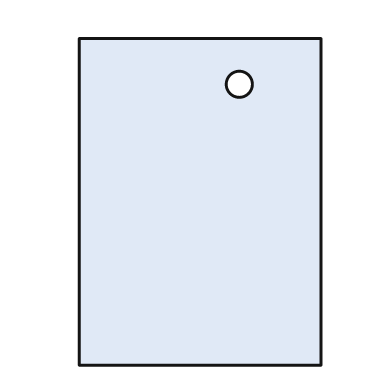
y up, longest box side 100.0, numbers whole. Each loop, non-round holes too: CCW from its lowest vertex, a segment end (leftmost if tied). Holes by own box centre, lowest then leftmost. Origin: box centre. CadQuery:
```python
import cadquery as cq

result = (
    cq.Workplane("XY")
    .moveTo(-37.0, -50.0)
    .lineTo(37.0, -50.0)
    .lineTo(37.0, 50.0)
    .lineTo(-37.0, 50.0)
    .close()
    .moveTo(12.0, 36.0)
    .circle(4.0)
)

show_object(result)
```